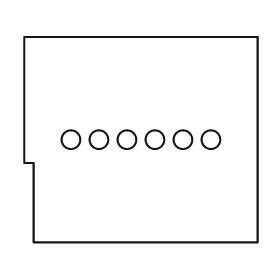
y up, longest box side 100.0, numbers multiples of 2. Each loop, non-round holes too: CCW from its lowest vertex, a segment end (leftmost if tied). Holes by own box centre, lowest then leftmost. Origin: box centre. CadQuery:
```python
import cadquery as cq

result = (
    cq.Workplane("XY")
    .moveTo(-46.0, -44.0)
    .lineTo(50.0, -44.0)
    .lineTo(50.0, 44.0)
    .lineTo(-50.0, 44.0)
    .lineTo(-50.0, -10.0)
    .lineTo(-46.0, -10.0)
    .close()
    .moveTo(-30.0, 0.0)
    .circle(4.0)
    .moveTo(-18.0, 0.0)
    .circle(4.0)
    .moveTo(-6.0, 0.0)
    .circle(4.0)
    .moveTo(6.0, 0.0)
    .circle(4.0)
    .moveTo(18.0, 0.0)
    .circle(4.0)
    .moveTo(30.0, 0.0)
    .circle(4.0)
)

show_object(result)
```